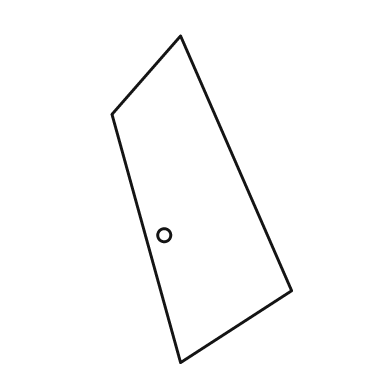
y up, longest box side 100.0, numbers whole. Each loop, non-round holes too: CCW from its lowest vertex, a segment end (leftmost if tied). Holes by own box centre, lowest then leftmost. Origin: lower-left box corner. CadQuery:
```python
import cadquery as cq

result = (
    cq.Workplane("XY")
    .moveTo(21.0, 0.0)
    .lineTo(55.0, 22.0)
    .lineTo(21.0, 100.0)
    .lineTo(0.0, 76.0)
    .close()
    .moveTo(16.0, 39.0)
    .circle(2.0)
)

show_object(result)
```